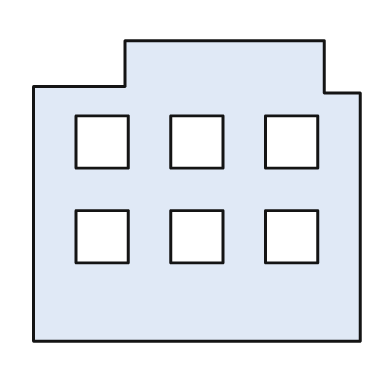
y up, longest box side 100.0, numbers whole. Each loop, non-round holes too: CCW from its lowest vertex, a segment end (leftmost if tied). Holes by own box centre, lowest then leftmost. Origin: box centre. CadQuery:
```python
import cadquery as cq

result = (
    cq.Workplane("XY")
    .moveTo(-50.0, -46.0)
    .lineTo(50.0, -46.0)
    .lineTo(50.0, 30.0)
    .lineTo(39.0, 30.0)
    .lineTo(39.0, 46.0)
    .lineTo(-22.0, 46.0)
    .lineTo(-22.0, 32.0)
    .lineTo(-50.0, 32.0)
    .close()
    .moveTo(-37.0, -22.0)
    .lineTo(-21.0, -22.0)
    .lineTo(-21.0, -6.0)
    .lineTo(-37.0, -6.0)
    .close()
    .moveTo(-8.0, -22.0)
    .lineTo(8.0, -22.0)
    .lineTo(8.0, -6.0)
    .lineTo(-8.0, -6.0)
    .close()
    .moveTo(21.0, -22.0)
    .lineTo(37.0, -22.0)
    .lineTo(37.0, -6.0)
    .lineTo(21.0, -6.0)
    .close()
    .moveTo(-37.0, 7.0)
    .lineTo(-21.0, 7.0)
    .lineTo(-21.0, 23.0)
    .lineTo(-37.0, 23.0)
    .close()
    .moveTo(-8.0, 7.0)
    .lineTo(8.0, 7.0)
    .lineTo(8.0, 23.0)
    .lineTo(-8.0, 23.0)
    .close()
    .moveTo(21.0, 7.0)
    .lineTo(37.0, 7.0)
    .lineTo(37.0, 23.0)
    .lineTo(21.0, 23.0)
    .close()
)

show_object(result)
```